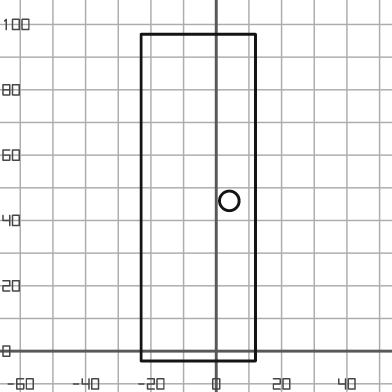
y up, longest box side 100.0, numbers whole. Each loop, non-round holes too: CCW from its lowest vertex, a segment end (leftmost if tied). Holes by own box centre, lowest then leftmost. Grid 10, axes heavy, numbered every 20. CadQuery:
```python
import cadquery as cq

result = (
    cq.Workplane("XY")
    .moveTo(-23.0, -3.0)
    .lineTo(12.0, -3.0)
    .lineTo(12.0, 97.0)
    .lineTo(-23.0, 97.0)
    .close()
    .moveTo(4.0, 46.0)
    .circle(3.0)
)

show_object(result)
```